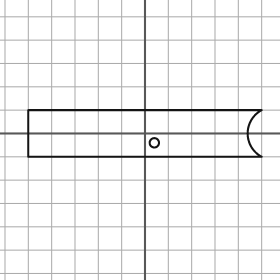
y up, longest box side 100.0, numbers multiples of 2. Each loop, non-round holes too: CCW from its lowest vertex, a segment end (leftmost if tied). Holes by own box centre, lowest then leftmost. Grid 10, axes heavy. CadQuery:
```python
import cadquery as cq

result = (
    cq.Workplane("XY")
    .moveTo(-50.0, -10.0)
    .lineTo(50.0, -10.0)
    .threePointArc((44.0, 0.0), (50.0, 10.0))
    .lineTo(-50.0, 10.0)
    .close()
    .moveTo(4.0, -4.0)
    .circle(2.0)
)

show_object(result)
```